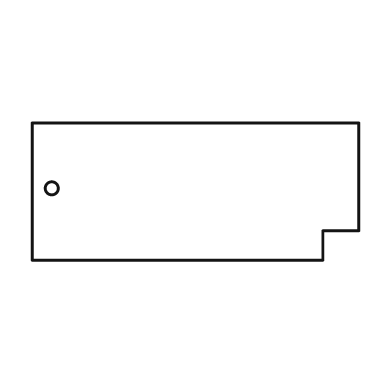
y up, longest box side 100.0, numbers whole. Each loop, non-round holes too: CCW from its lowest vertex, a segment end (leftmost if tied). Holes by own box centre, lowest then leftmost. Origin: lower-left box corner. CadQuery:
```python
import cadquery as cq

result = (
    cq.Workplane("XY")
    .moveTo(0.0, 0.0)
    .lineTo(89.0, 0.0)
    .lineTo(89.0, 9.0)
    .lineTo(100.0, 9.0)
    .lineTo(100.0, 42.0)
    .lineTo(0.0, 42.0)
    .close()
    .moveTo(6.0, 22.0)
    .circle(2.0)
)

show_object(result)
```